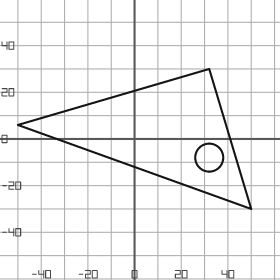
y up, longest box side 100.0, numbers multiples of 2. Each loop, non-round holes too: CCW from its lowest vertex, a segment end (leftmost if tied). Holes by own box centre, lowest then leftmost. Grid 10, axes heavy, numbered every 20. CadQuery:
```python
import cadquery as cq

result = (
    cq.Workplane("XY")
    .moveTo(50.0, -30.0)
    .lineTo(32.0, 30.0)
    .lineTo(-50.0, 6.0)
    .close()
    .moveTo(32.0, -8.0)
    .circle(6.0)
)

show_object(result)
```